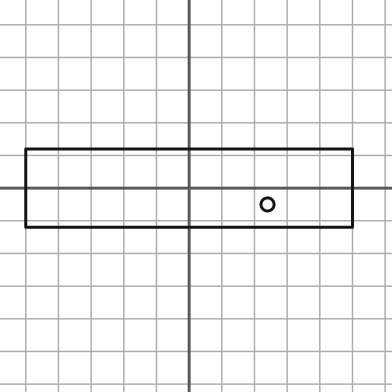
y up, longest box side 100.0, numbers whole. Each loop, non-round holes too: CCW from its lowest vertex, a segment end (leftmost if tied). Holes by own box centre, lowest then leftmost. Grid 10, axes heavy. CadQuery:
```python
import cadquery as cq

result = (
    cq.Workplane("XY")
    .moveTo(-50.0, -12.0)
    .lineTo(50.0, -12.0)
    .lineTo(50.0, 12.0)
    .lineTo(-50.0, 12.0)
    .close()
    .moveTo(24.0, -5.0)
    .circle(2.0)
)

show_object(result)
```